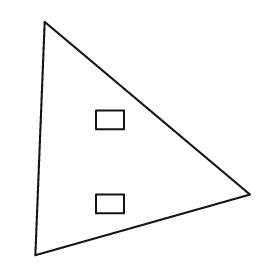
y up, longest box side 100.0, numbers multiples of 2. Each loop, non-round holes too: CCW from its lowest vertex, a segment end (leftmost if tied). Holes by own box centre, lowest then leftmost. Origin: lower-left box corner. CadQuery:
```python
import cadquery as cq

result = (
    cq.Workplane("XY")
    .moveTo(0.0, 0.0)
    .lineTo(92.0, 26.0)
    .lineTo(4.0, 100.0)
    .close()
    .moveTo(26.0, 18.0)
    .lineTo(38.0, 18.0)
    .lineTo(38.0, 26.0)
    .lineTo(26.0, 26.0)
    .close()
    .moveTo(26.0, 54.0)
    .lineTo(38.0, 54.0)
    .lineTo(38.0, 62.0)
    .lineTo(26.0, 62.0)
    .close()
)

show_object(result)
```